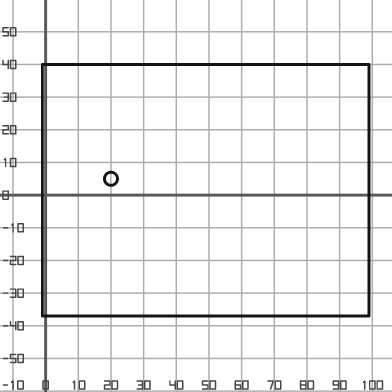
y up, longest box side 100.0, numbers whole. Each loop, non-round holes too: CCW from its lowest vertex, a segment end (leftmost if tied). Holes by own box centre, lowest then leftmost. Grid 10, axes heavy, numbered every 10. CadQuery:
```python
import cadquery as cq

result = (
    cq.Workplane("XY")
    .moveTo(-1.0, -37.0)
    .lineTo(99.0, -37.0)
    .lineTo(99.0, 40.0)
    .lineTo(-1.0, 40.0)
    .close()
    .moveTo(20.0, 5.0)
    .circle(2.0)
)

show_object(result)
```